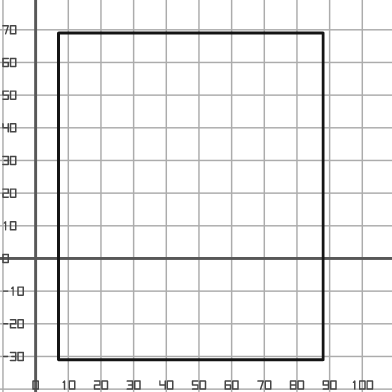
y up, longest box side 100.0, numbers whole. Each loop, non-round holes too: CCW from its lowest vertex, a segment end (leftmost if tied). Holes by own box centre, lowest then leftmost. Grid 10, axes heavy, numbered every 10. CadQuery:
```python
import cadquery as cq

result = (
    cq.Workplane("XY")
    .moveTo(7.0, -31.0)
    .lineTo(88.0, -31.0)
    .lineTo(88.0, 69.0)
    .lineTo(7.0, 69.0)
    .close()
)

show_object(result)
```